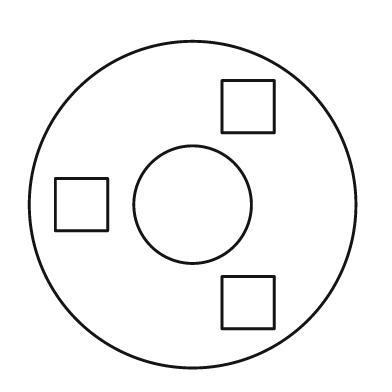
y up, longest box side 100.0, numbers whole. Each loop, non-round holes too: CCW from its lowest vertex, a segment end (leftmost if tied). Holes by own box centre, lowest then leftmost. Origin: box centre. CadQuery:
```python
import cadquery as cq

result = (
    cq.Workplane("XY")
    .moveTo(0.0, 0.0)
    .circle(50.0)
    .moveTo(9.0, -38.0)
    .lineTo(25.0, -38.0)
    .lineTo(25.0, -22.0)
    .lineTo(9.0, -22.0)
    .close()
    .moveTo(-42.0, -8.0)
    .lineTo(-26.0, -8.0)
    .lineTo(-26.0, 8.0)
    .lineTo(-42.0, 8.0)
    .close()
    .moveTo(0.0, 0.0)
    .circle(18.0)
    .moveTo(9.0, 22.0)
    .lineTo(25.0, 22.0)
    .lineTo(25.0, 38.0)
    .lineTo(9.0, 38.0)
    .close()
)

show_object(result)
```